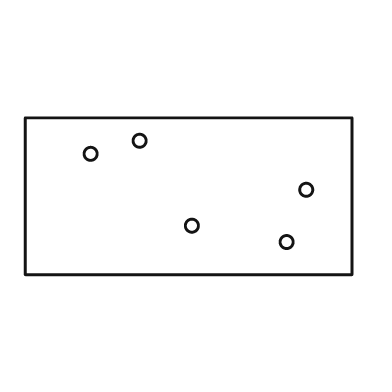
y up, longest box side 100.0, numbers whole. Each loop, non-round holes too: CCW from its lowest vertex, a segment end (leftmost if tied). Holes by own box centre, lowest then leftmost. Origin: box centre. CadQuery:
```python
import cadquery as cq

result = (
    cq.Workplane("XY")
    .moveTo(-50.0, -24.0)
    .lineTo(50.0, -24.0)
    .lineTo(50.0, 24.0)
    .lineTo(-50.0, 24.0)
    .close()
    .moveTo(30.0, -14.0)
    .circle(2.0)
    .moveTo(1.0, -9.0)
    .circle(2.0)
    .moveTo(36.0, 2.0)
    .circle(2.0)
    .moveTo(-30.0, 13.0)
    .circle(2.0)
    .moveTo(-15.0, 17.0)
    .circle(2.0)
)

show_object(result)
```